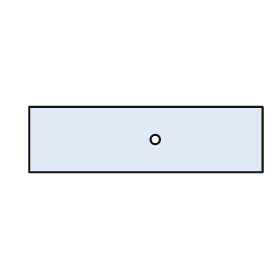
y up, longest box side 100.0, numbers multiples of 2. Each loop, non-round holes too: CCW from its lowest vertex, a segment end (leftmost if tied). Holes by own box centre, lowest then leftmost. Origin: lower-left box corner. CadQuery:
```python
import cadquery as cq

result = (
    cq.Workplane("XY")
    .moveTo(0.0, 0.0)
    .lineTo(100.0, 0.0)
    .lineTo(100.0, 28.0)
    .lineTo(0.0, 28.0)
    .close()
    .moveTo(54.0, 14.0)
    .circle(2.0)
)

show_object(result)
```